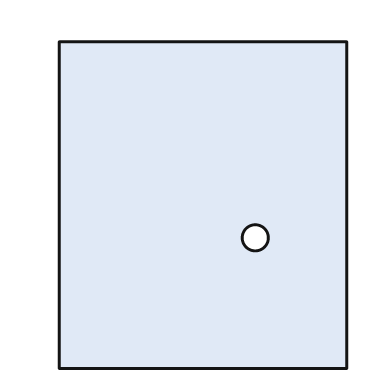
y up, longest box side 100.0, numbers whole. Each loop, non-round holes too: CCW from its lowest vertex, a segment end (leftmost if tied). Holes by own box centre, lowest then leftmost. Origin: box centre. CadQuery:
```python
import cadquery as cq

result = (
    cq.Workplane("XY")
    .moveTo(-44.0, -50.0)
    .lineTo(44.0, -50.0)
    .lineTo(44.0, 50.0)
    .lineTo(-44.0, 50.0)
    .close()
    .moveTo(16.0, -10.0)
    .circle(4.0)
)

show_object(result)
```